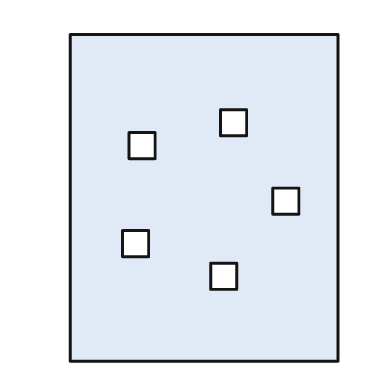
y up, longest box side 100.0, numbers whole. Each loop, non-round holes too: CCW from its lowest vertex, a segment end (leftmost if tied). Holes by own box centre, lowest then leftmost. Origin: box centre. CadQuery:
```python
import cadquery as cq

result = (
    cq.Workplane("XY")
    .moveTo(-41.0, -50.0)
    .lineTo(41.0, -50.0)
    .lineTo(41.0, 50.0)
    .lineTo(-41.0, 50.0)
    .close()
    .moveTo(2.0, -28.0)
    .lineTo(10.0, -28.0)
    .lineTo(10.0, -20.0)
    .lineTo(2.0, -20.0)
    .close()
    .moveTo(-25.0, -18.0)
    .lineTo(-17.0, -18.0)
    .lineTo(-17.0, -10.0)
    .lineTo(-25.0, -10.0)
    .close()
    .moveTo(21.0, -5.0)
    .lineTo(29.0, -5.0)
    .lineTo(29.0, 3.0)
    .lineTo(21.0, 3.0)
    .close()
    .moveTo(-23.0, 12.0)
    .lineTo(-15.0, 12.0)
    .lineTo(-15.0, 20.0)
    .lineTo(-23.0, 20.0)
    .close()
    .moveTo(5.0, 19.0)
    .lineTo(13.0, 19.0)
    .lineTo(13.0, 27.0)
    .lineTo(5.0, 27.0)
    .close()
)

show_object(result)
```